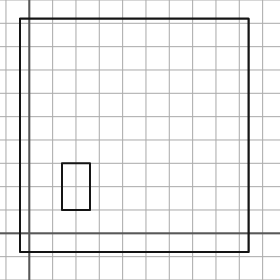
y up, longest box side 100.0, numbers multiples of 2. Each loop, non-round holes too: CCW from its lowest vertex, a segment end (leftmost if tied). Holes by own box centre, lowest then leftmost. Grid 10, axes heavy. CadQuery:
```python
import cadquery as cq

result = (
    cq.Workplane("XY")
    .moveTo(-4.0, -8.0)
    .lineTo(94.0, -8.0)
    .lineTo(94.0, 92.0)
    .lineTo(-4.0, 92.0)
    .close()
    .moveTo(14.0, 10.0)
    .lineTo(26.0, 10.0)
    .lineTo(26.0, 30.0)
    .lineTo(14.0, 30.0)
    .close()
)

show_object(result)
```